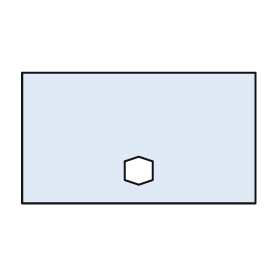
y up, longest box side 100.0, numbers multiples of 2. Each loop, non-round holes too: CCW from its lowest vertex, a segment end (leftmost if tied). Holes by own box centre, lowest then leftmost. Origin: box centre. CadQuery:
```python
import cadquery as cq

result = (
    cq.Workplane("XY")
    .moveTo(-50.0, -28.0)
    .lineTo(50.0, -28.0)
    .lineTo(50.0, 28.0)
    .lineTo(-50.0, 28.0)
    .close()
    .moveTo(0.0, -20.0)
    .lineTo(6.0, -18.0)
    .lineTo(6.0, -10.0)
    .lineTo(0.0, -8.0)
    .lineTo(-6.0, -10.0)
    .lineTo(-6.0, -18.0)
    .close()
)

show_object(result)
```